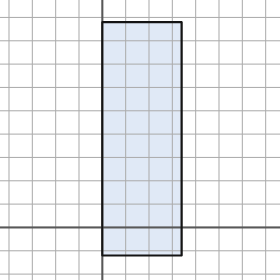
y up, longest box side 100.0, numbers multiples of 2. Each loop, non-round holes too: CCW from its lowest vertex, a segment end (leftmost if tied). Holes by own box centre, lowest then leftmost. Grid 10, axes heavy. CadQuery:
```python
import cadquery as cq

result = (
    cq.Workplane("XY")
    .moveTo(0.0, -12.0)
    .lineTo(34.0, -12.0)
    .lineTo(34.0, 88.0)
    .lineTo(0.0, 88.0)
    .close()
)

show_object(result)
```